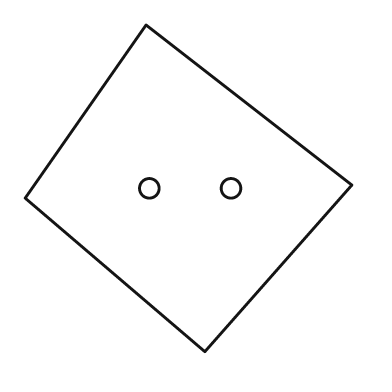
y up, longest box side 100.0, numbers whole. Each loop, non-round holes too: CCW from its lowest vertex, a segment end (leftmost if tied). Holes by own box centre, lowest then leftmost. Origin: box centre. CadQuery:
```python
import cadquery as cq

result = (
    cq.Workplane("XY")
    .moveTo(5.0, -50.0)
    .lineTo(50.0, 1.0)
    .lineTo(-13.0, 50.0)
    .lineTo(-50.0, -3.0)
    .close()
    .moveTo(-12.0, 0.0)
    .circle(3.0)
    .moveTo(13.0, 0.0)
    .circle(3.0)
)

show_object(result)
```